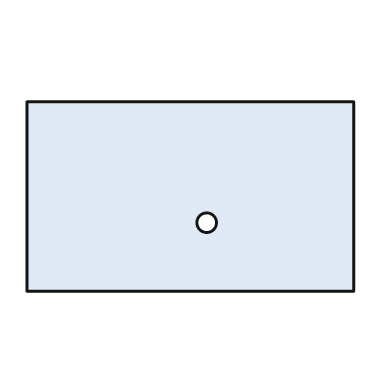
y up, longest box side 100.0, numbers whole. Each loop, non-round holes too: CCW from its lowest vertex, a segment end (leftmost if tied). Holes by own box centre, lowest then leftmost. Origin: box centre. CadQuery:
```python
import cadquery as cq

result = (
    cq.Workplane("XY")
    .moveTo(-50.0, -29.0)
    .lineTo(50.0, -29.0)
    .lineTo(50.0, 29.0)
    .lineTo(-50.0, 29.0)
    .close()
    .moveTo(5.0, -8.0)
    .circle(3.0)
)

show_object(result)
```